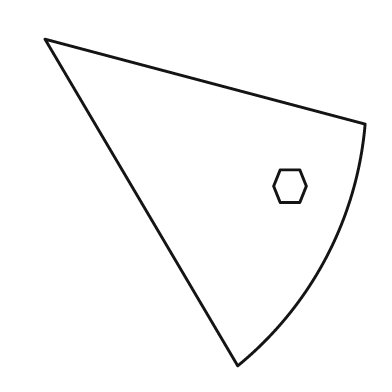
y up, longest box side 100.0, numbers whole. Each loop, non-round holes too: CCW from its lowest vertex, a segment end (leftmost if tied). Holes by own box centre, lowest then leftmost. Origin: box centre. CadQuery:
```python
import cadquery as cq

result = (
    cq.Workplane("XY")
    .moveTo(10.0, -50.0)
    .threePointArc((37.0, -17.0), (49.0, 24.0))
    .lineTo(-49.0, 50.0)
    .close()
    .moveTo(23.0, 0.0)
    .lineTo(29.0, 0.0)
    .lineTo(31.0, 5.0)
    .lineTo(29.0, 10.0)
    .lineTo(23.0, 10.0)
    .lineTo(21.0, 5.0)
    .close()
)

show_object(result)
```